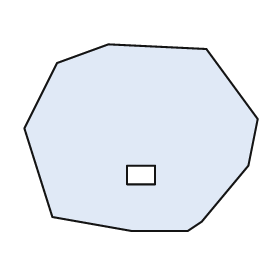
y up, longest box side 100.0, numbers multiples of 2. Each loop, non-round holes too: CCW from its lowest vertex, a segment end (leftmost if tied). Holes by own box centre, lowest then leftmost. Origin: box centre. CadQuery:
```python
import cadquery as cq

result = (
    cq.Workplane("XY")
    .moveTo(-4.0, -40.0)
    .lineTo(20.0, -40.0)
    .lineTo(26.0, -36.0)
    .lineTo(46.0, -12.0)
    .lineTo(50.0, 8.0)
    .lineTo(28.0, 38.0)
    .lineTo(-14.0, 40.0)
    .lineTo(-36.0, 32.0)
    .lineTo(-50.0, 4.0)
    .lineTo(-38.0, -34.0)
    .close()
    .moveTo(-6.0, -20.0)
    .lineTo(6.0, -20.0)
    .lineTo(6.0, -12.0)
    .lineTo(-6.0, -12.0)
    .close()
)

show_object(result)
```